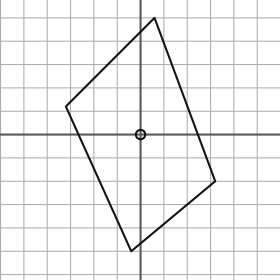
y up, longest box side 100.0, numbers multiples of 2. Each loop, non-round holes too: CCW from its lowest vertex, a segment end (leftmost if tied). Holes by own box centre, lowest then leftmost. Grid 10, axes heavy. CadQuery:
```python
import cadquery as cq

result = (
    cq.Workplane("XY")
    .moveTo(-4.0, -50.0)
    .lineTo(32.0, -20.0)
    .lineTo(6.0, 50.0)
    .lineTo(-32.0, 12.0)
    .close()
    .moveTo(0.0, 0.0)
    .circle(2.0)
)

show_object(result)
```